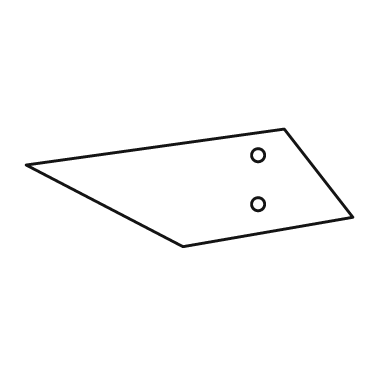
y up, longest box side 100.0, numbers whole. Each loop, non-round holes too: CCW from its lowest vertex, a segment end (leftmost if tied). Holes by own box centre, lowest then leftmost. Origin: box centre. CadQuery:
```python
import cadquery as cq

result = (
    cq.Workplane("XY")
    .moveTo(-2.0, -18.0)
    .lineTo(50.0, -9.0)
    .lineTo(29.0, 18.0)
    .lineTo(-50.0, 7.0)
    .close()
    .moveTo(21.0, -5.0)
    .circle(2.0)
    .moveTo(21.0, 10.0)
    .circle(2.0)
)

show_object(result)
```